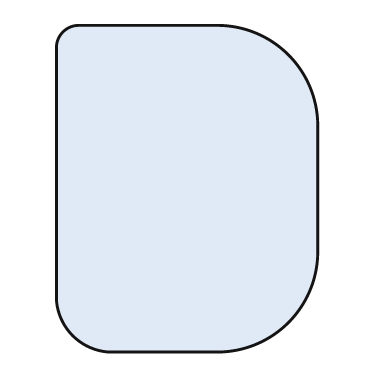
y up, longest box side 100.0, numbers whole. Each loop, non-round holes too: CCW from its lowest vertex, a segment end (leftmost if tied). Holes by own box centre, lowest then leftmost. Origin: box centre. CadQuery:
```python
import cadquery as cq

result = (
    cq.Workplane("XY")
    .moveTo(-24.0, -50.0)
    .lineTo(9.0, -50.0)
    .threePointArc((31.0, -41.0), (40.0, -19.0))
    .lineTo(40.0, 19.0)
    .threePointArc((31.0, 41.0), (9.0, 50.0))
    .lineTo(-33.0, 50.0)
    .threePointArc((-38.0, 48.0), (-40.0, 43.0))
    .lineTo(-40.0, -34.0)
    .threePointArc((-35.0, -45.0), (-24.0, -50.0))
    .close()
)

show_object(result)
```